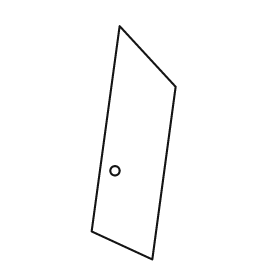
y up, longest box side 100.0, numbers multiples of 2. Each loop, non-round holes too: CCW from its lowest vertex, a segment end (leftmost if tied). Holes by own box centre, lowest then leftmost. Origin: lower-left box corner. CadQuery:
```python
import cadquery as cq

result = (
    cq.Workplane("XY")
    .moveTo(26.0, 0.0)
    .lineTo(36.0, 74.0)
    .lineTo(12.0, 100.0)
    .lineTo(0.0, 12.0)
    .close()
    .moveTo(10.0, 38.0)
    .circle(2.0)
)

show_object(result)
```